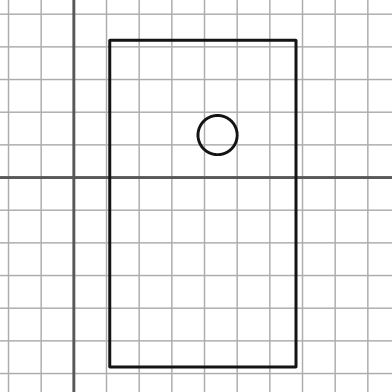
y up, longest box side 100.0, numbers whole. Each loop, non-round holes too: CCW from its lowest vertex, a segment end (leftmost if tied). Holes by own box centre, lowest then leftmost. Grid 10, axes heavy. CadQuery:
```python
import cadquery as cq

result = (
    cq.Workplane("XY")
    .moveTo(11.0, -58.0)
    .lineTo(68.0, -58.0)
    .lineTo(68.0, 42.0)
    .lineTo(11.0, 42.0)
    .close()
    .moveTo(44.0, 13.0)
    .circle(6.0)
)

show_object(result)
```